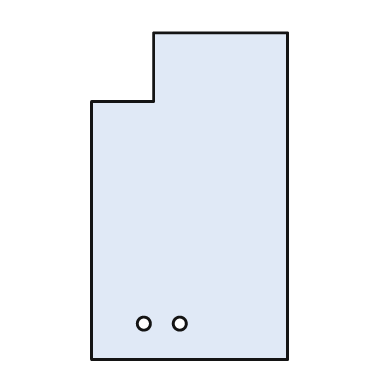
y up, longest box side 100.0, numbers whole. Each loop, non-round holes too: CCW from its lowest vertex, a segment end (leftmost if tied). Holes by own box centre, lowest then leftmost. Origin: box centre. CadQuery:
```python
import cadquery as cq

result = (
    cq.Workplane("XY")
    .moveTo(-30.0, -50.0)
    .lineTo(30.0, -50.0)
    .lineTo(30.0, 50.0)
    .lineTo(-11.0, 50.0)
    .lineTo(-11.0, 29.0)
    .lineTo(-30.0, 29.0)
    .close()
    .moveTo(-14.0, -39.0)
    .circle(2.0)
    .moveTo(-3.0, -39.0)
    .circle(2.0)
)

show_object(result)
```